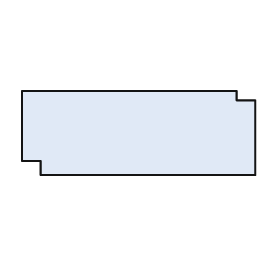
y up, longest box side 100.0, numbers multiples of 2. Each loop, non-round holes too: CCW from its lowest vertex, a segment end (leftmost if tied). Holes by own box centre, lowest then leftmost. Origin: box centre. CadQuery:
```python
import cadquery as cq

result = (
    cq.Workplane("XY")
    .moveTo(-42.0, -18.0)
    .lineTo(50.0, -18.0)
    .lineTo(50.0, 14.0)
    .lineTo(42.0, 14.0)
    .lineTo(42.0, 18.0)
    .lineTo(-50.0, 18.0)
    .lineTo(-50.0, -12.0)
    .lineTo(-42.0, -12.0)
    .close()
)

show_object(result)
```